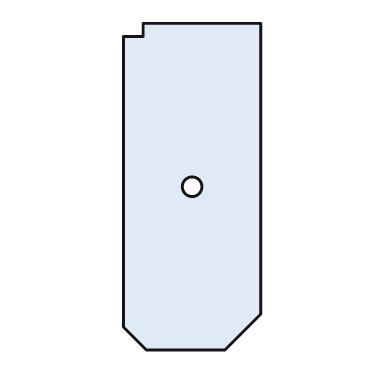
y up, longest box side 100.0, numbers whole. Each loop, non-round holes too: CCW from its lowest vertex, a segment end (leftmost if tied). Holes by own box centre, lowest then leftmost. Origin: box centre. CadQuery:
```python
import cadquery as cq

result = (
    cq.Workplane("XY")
    .moveTo(-14.0, -50.0)
    .lineTo(10.0, -50.0)
    .lineTo(21.0, -39.0)
    .lineTo(21.0, 50.0)
    .lineTo(-15.0, 50.0)
    .lineTo(-15.0, 46.0)
    .lineTo(-21.0, 46.0)
    .lineTo(-21.0, -43.0)
    .close()
    .moveTo(0.0, 0.0)
    .circle(3.0)
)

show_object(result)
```